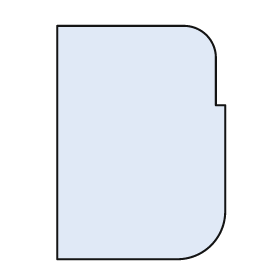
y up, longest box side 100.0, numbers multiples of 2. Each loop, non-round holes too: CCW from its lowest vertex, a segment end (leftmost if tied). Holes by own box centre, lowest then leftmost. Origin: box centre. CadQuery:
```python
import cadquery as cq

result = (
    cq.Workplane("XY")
    .moveTo(-36.0, -50.0)
    .lineTo(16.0, -50.0)
    .threePointArc((30.0, -44.0), (36.0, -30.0))
    .lineTo(36.0, 16.0)
    .lineTo(32.0, 16.0)
    .lineTo(32.0, 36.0)
    .threePointArc((28.0, 46.0), (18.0, 50.0))
    .lineTo(-36.0, 50.0)
    .close()
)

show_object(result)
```